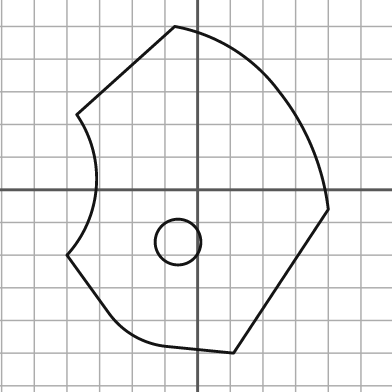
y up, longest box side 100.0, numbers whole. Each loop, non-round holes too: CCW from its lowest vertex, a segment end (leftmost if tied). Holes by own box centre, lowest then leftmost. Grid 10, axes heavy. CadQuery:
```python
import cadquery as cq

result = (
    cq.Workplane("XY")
    .moveTo(11.0, -50.0)
    .lineTo(40.0, -6.0)
    .threePointArc((35.0, 13.0), (25.0, 30.0))
    .threePointArc((11.0, 43.0), (-7.0, 50.0))
    .lineTo(-37.0, 23.0)
    .threePointArc((-31.0, 1.0), (-40.0, -20.0))
    .lineTo(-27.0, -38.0)
    .threePointArc((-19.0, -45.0), (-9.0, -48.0))
    .close()
    .moveTo(-6.0, -16.0)
    .circle(7.0)
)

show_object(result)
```